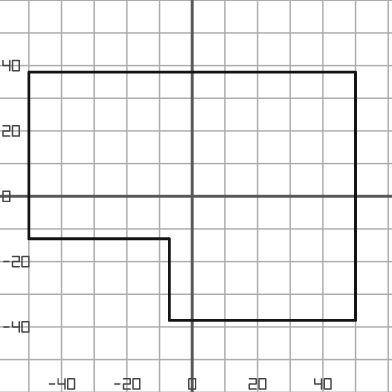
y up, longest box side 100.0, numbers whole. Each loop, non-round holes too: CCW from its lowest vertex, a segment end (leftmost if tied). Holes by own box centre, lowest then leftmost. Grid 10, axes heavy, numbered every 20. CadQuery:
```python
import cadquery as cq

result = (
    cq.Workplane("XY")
    .moveTo(-7.0, -38.0)
    .lineTo(50.0, -38.0)
    .lineTo(50.0, 38.0)
    .lineTo(-50.0, 38.0)
    .lineTo(-50.0, -13.0)
    .lineTo(-7.0, -13.0)
    .close()
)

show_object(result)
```